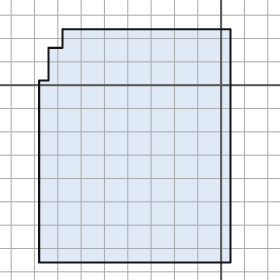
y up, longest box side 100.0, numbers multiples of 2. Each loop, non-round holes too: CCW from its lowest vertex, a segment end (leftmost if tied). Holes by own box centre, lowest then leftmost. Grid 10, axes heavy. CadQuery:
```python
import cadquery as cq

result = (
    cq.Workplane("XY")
    .moveTo(-78.0, -76.0)
    .lineTo(4.0, -76.0)
    .lineTo(4.0, 24.0)
    .lineTo(-68.0, 24.0)
    .lineTo(-68.0, 16.0)
    .lineTo(-74.0, 16.0)
    .lineTo(-74.0, 2.0)
    .lineTo(-78.0, 2.0)
    .close()
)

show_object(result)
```